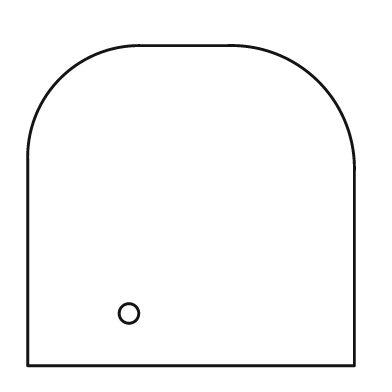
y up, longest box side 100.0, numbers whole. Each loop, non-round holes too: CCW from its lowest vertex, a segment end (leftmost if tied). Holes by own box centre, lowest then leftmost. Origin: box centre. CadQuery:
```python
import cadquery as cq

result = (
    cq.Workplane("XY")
    .moveTo(-50.0, -49.0)
    .lineTo(50.0, -49.0)
    .lineTo(50.0, 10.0)
    .threePointArc((39.0, 38.0), (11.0, 49.0))
    .lineTo(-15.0, 49.0)
    .threePointArc((-40.0, 39.0), (-50.0, 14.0))
    .close()
    .moveTo(-19.0, -33.0)
    .circle(3.0)
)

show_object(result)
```